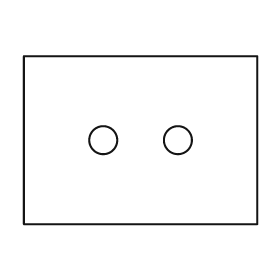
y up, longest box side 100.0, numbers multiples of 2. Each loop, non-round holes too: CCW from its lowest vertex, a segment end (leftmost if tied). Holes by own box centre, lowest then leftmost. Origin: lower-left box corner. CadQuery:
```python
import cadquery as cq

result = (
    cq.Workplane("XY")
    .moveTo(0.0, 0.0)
    .lineTo(100.0, 0.0)
    .lineTo(100.0, 72.0)
    .lineTo(0.0, 72.0)
    .close()
    .moveTo(34.0, 36.0)
    .circle(6.0)
    .moveTo(66.0, 36.0)
    .circle(6.0)
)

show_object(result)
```